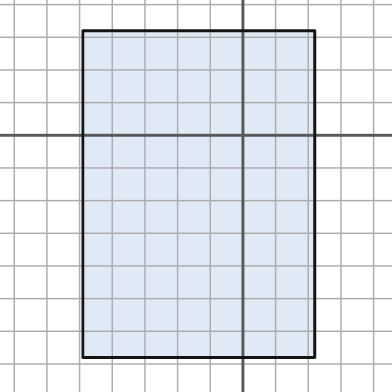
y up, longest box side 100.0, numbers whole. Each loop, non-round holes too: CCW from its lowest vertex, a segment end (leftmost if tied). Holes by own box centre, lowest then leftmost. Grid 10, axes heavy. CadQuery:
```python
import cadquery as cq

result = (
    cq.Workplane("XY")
    .moveTo(-49.0, -68.0)
    .lineTo(22.0, -68.0)
    .lineTo(22.0, 32.0)
    .lineTo(-49.0, 32.0)
    .close()
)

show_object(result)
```